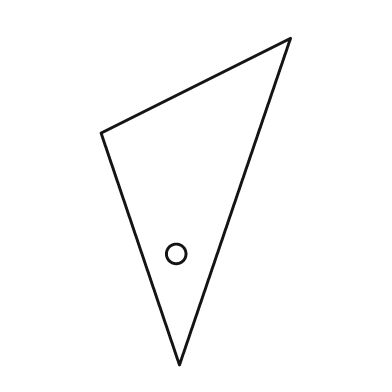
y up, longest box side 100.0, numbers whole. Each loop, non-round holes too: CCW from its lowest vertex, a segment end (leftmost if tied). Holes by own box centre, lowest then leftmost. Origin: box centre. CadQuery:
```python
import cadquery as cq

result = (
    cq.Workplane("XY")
    .moveTo(-5.0, -50.0)
    .lineTo(29.0, 50.0)
    .lineTo(-29.0, 21.0)
    .close()
    .moveTo(-6.0, -16.0)
    .circle(3.0)
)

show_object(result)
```